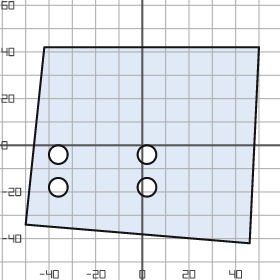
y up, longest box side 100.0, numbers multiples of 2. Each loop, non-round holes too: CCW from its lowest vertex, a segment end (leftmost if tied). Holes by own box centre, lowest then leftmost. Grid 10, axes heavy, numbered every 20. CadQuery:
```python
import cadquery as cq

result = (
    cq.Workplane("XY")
    .moveTo(46.0, -42.0)
    .lineTo(50.0, 42.0)
    .lineTo(-42.0, 42.0)
    .lineTo(-50.0, -34.0)
    .close()
    .moveTo(-36.0, -18.0)
    .circle(4.0)
    .moveTo(2.0, -18.0)
    .circle(4.0)
    .moveTo(-36.0, -4.0)
    .circle(4.0)
    .moveTo(2.0, -4.0)
    .circle(4.0)
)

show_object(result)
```